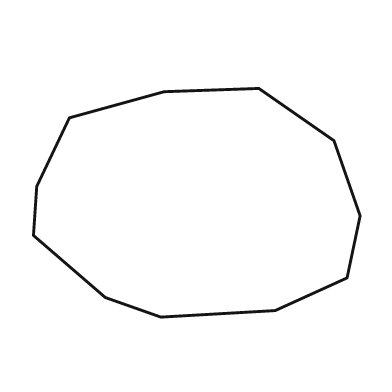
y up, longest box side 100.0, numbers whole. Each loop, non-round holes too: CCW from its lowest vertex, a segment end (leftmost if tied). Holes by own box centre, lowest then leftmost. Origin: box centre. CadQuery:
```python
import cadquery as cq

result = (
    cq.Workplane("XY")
    .moveTo(-11.0, -35.0)
    .lineTo(24.0, -33.0)
    .lineTo(46.0, -23.0)
    .lineTo(50.0, -4.0)
    .lineTo(42.0, 19.0)
    .lineTo(19.0, 35.0)
    .lineTo(-10.0, 34.0)
    .lineTo(-39.0, 26.0)
    .lineTo(-49.0, 5.0)
    .lineTo(-50.0, -10.0)
    .lineTo(-28.0, -29.0)
    .close()
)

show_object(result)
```